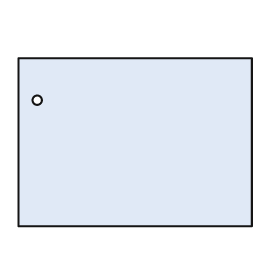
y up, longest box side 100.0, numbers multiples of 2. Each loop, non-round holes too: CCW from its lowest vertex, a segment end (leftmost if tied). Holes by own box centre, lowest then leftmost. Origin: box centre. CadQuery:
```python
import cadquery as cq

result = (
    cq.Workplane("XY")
    .moveTo(-50.0, -36.0)
    .lineTo(50.0, -36.0)
    .lineTo(50.0, 36.0)
    .lineTo(-50.0, 36.0)
    .close()
    .moveTo(-42.0, 18.0)
    .circle(2.0)
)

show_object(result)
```